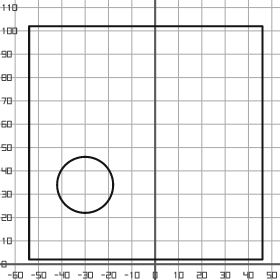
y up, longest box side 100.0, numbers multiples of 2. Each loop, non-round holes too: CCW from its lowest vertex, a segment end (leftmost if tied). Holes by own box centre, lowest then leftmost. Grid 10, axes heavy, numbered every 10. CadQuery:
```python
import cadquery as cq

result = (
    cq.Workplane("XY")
    .moveTo(-54.0, 2.0)
    .lineTo(46.0, 2.0)
    .lineTo(46.0, 102.0)
    .lineTo(-54.0, 102.0)
    .close()
    .moveTo(-30.0, 34.0)
    .circle(12.0)
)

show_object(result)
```